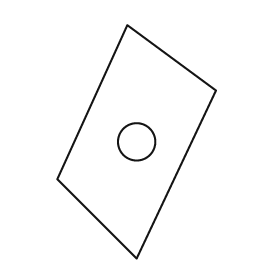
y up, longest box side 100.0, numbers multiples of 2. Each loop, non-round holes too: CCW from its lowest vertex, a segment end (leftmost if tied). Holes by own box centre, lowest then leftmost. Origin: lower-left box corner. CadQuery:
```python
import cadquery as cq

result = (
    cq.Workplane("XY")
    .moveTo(34.0, 0.0)
    .lineTo(68.0, 72.0)
    .lineTo(30.0, 100.0)
    .lineTo(0.0, 34.0)
    .close()
    .moveTo(34.0, 50.0)
    .circle(8.0)
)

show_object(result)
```